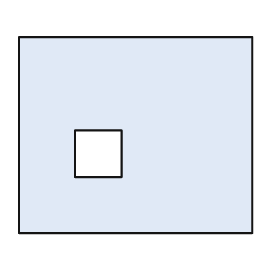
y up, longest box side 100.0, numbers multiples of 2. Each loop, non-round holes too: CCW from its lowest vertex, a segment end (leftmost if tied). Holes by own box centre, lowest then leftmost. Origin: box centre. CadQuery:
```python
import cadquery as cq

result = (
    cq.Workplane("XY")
    .moveTo(-50.0, -42.0)
    .lineTo(50.0, -42.0)
    .lineTo(50.0, 42.0)
    .lineTo(-50.0, 42.0)
    .close()
    .moveTo(-26.0, -18.0)
    .lineTo(-6.0, -18.0)
    .lineTo(-6.0, 2.0)
    .lineTo(-26.0, 2.0)
    .close()
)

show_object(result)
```